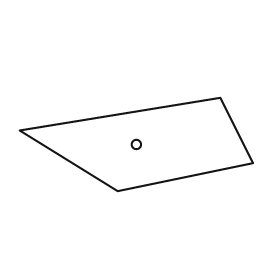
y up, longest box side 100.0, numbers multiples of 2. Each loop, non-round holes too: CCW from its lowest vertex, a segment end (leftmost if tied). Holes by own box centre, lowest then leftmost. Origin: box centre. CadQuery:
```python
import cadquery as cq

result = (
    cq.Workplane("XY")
    .moveTo(-8.0, -20.0)
    .lineTo(50.0, -8.0)
    .lineTo(36.0, 20.0)
    .lineTo(-50.0, 6.0)
    .close()
    .moveTo(0.0, 0.0)
    .circle(2.0)
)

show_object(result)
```